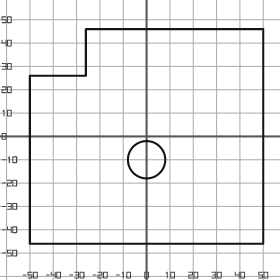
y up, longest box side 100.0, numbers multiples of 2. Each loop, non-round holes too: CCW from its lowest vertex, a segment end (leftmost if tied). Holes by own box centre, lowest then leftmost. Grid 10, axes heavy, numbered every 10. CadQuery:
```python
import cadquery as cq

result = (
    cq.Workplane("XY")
    .moveTo(-50.0, -46.0)
    .lineTo(50.0, -46.0)
    .lineTo(50.0, 46.0)
    .lineTo(-26.0, 46.0)
    .lineTo(-26.0, 26.0)
    .lineTo(-50.0, 26.0)
    .close()
    .moveTo(0.0, -10.0)
    .circle(8.0)
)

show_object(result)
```